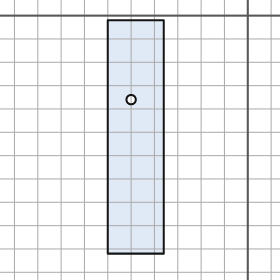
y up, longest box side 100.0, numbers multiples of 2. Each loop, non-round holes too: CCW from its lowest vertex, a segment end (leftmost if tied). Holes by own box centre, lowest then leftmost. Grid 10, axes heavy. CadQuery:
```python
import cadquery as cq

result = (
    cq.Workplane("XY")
    .moveTo(-60.0, -102.0)
    .lineTo(-36.0, -102.0)
    .lineTo(-36.0, -2.0)
    .lineTo(-60.0, -2.0)
    .close()
    .moveTo(-50.0, -36.0)
    .circle(2.0)
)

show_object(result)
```